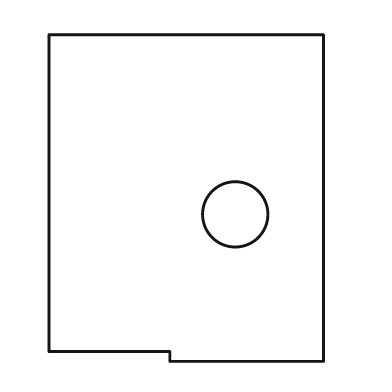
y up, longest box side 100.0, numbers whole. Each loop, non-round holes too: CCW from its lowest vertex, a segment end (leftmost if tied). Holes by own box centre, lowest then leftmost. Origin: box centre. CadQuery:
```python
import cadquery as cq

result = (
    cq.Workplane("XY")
    .moveTo(-5.0, -50.0)
    .lineTo(42.0, -50.0)
    .lineTo(42.0, 50.0)
    .lineTo(-42.0, 50.0)
    .lineTo(-42.0, -47.0)
    .lineTo(-5.0, -47.0)
    .close()
    .moveTo(15.0, -5.0)
    .circle(10.0)
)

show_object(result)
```